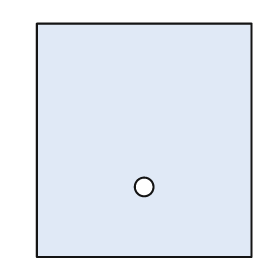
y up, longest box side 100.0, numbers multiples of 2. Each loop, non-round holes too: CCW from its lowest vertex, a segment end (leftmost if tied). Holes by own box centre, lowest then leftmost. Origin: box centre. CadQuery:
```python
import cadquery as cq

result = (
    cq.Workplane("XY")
    .moveTo(-46.0, -50.0)
    .lineTo(46.0, -50.0)
    .lineTo(46.0, 50.0)
    .lineTo(-46.0, 50.0)
    .close()
    .moveTo(0.0, -20.0)
    .circle(4.0)
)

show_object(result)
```